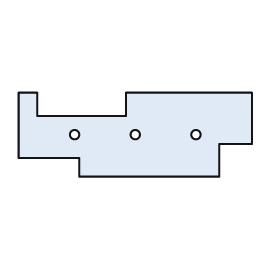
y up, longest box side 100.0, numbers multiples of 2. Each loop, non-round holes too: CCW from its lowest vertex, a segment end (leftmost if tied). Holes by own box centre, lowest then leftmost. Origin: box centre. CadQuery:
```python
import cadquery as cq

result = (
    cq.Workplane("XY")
    .moveTo(-24.0, -18.0)
    .lineTo(36.0, -18.0)
    .lineTo(36.0, -4.0)
    .lineTo(50.0, -4.0)
    .lineTo(50.0, 18.0)
    .lineTo(-4.0, 18.0)
    .lineTo(-4.0, 8.0)
    .lineTo(-42.0, 8.0)
    .lineTo(-42.0, 18.0)
    .lineTo(-50.0, 18.0)
    .lineTo(-50.0, -10.0)
    .lineTo(-24.0, -10.0)
    .close()
    .moveTo(-26.0, 0.0)
    .circle(2.0)
    .moveTo(0.0, 0.0)
    .circle(2.0)
    .moveTo(26.0, 0.0)
    .circle(2.0)
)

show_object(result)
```